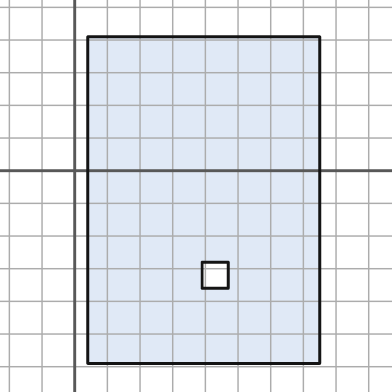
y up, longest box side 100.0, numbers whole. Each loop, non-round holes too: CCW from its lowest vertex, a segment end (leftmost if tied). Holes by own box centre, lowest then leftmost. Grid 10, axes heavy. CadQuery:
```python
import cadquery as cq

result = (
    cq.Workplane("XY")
    .moveTo(4.0, -59.0)
    .lineTo(75.0, -59.0)
    .lineTo(75.0, 41.0)
    .lineTo(4.0, 41.0)
    .close()
    .moveTo(39.0, -36.0)
    .lineTo(47.0, -36.0)
    .lineTo(47.0, -28.0)
    .lineTo(39.0, -28.0)
    .close()
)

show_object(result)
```